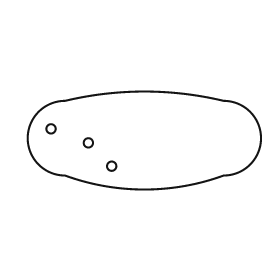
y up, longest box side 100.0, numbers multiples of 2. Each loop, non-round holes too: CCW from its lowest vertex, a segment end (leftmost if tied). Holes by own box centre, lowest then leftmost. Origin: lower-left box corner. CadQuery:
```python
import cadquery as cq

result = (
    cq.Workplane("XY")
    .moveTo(16.0, 6.0)
    .threePointArc((50.0, 0.0), (84.0, 6.0))
    .threePointArc((100.0, 22.0), (84.0, 38.0))
    .threePointArc((50.0, 42.0), (16.0, 38.0))
    .threePointArc((0.0, 22.0), (16.0, 6.0))
    .close()
    .moveTo(36.0, 10.0)
    .circle(2.0)
    .moveTo(26.0, 20.0)
    .circle(2.0)
    .moveTo(10.0, 26.0)
    .circle(2.0)
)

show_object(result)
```